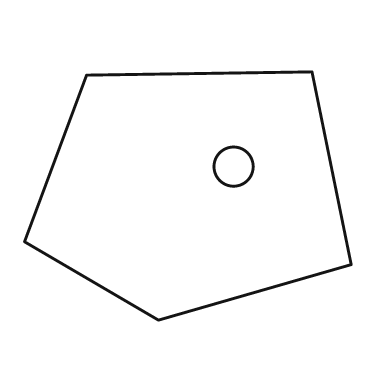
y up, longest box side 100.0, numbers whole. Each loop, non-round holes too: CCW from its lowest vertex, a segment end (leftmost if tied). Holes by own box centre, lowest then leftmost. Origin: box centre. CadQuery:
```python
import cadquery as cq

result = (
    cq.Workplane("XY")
    .moveTo(-9.0, -38.0)
    .lineTo(50.0, -21.0)
    .lineTo(38.0, 38.0)
    .lineTo(-31.0, 37.0)
    .lineTo(-50.0, -14.0)
    .close()
    .moveTo(14.0, 9.0)
    .circle(6.0)
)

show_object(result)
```